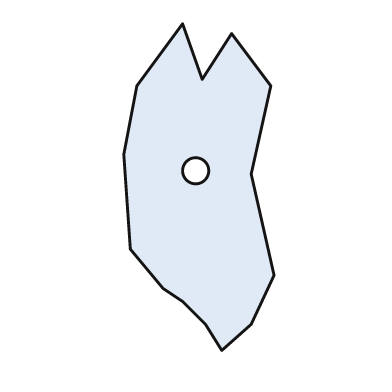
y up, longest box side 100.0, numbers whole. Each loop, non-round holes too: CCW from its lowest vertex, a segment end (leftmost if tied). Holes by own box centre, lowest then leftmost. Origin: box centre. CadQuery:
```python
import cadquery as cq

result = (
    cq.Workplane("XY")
    .moveTo(7.0, -50.0)
    .lineTo(16.0, -42.0)
    .lineTo(23.0, -27.0)
    .lineTo(16.0, 4.0)
    .lineTo(22.0, 31.0)
    .lineTo(10.0, 47.0)
    .lineTo(1.0, 33.0)
    .lineTo(-5.0, 50.0)
    .lineTo(-19.0, 31.0)
    .lineTo(-23.0, 10.0)
    .lineTo(-21.0, -19.0)
    .lineTo(-11.0, -31.0)
    .lineTo(-5.0, -35.0)
    .lineTo(2.0, -42.0)
    .close()
    .moveTo(-1.0, 5.0)
    .circle(4.0)
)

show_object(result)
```